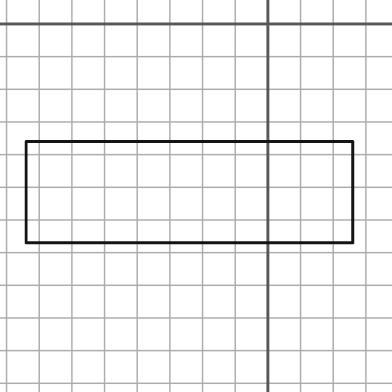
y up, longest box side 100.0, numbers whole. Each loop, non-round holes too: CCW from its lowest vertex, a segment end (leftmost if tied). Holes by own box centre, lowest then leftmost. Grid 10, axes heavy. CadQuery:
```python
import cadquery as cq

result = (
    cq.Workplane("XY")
    .moveTo(-74.0, -67.0)
    .lineTo(26.0, -67.0)
    .lineTo(26.0, -36.0)
    .lineTo(-74.0, -36.0)
    .close()
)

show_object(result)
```